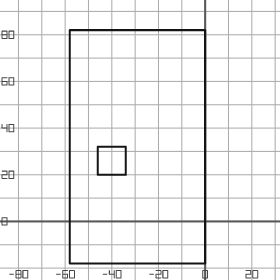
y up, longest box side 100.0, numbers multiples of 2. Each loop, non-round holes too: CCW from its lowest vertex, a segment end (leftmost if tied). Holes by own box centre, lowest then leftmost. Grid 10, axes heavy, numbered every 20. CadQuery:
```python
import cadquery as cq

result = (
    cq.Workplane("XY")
    .moveTo(-58.0, -18.0)
    .lineTo(0.0, -18.0)
    .lineTo(0.0, 82.0)
    .lineTo(-58.0, 82.0)
    .close()
    .moveTo(-46.0, 20.0)
    .lineTo(-34.0, 20.0)
    .lineTo(-34.0, 32.0)
    .lineTo(-46.0, 32.0)
    .close()
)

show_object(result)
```